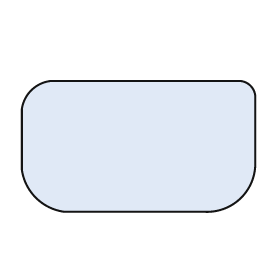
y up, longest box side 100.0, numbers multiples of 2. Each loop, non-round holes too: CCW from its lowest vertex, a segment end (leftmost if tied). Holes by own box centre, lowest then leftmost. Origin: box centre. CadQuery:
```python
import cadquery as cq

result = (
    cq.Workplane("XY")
    .moveTo(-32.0, -28.0)
    .lineTo(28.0, -28.0)
    .threePointArc((44.0, -22.0), (50.0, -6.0))
    .lineTo(50.0, 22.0)
    .threePointArc((48.0, 26.0), (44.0, 28.0))
    .lineTo(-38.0, 28.0)
    .threePointArc((-46.0, 24.0), (-50.0, 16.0))
    .lineTo(-50.0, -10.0)
    .threePointArc((-44.0, -22.0), (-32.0, -28.0))
    .close()
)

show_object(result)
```